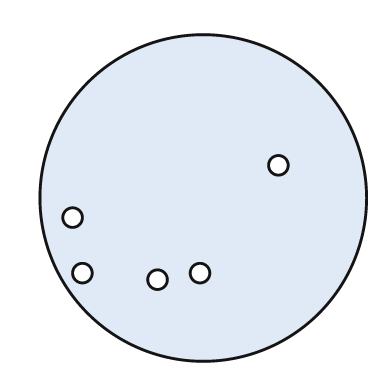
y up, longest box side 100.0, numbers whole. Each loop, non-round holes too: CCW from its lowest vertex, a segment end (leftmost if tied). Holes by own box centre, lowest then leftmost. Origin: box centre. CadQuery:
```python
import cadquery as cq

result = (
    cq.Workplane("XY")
    .moveTo(0.0, 0.0)
    .circle(50.0)
    .moveTo(-14.0, -25.0)
    .circle(3.0)
    .moveTo(-37.0, -23.0)
    .circle(3.0)
    .moveTo(-1.0, -23.0)
    .circle(3.0)
    .moveTo(-40.0, -6.0)
    .circle(3.0)
    .moveTo(23.0, 10.0)
    .circle(3.0)
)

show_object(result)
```